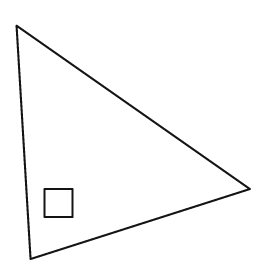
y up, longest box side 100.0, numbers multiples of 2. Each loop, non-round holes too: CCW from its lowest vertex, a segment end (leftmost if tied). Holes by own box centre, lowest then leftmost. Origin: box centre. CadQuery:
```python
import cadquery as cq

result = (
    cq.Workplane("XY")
    .moveTo(-44.0, -50.0)
    .lineTo(50.0, -20.0)
    .lineTo(-50.0, 50.0)
    .close()
    .moveTo(-38.0, -32.0)
    .lineTo(-26.0, -32.0)
    .lineTo(-26.0, -20.0)
    .lineTo(-38.0, -20.0)
    .close()
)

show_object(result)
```